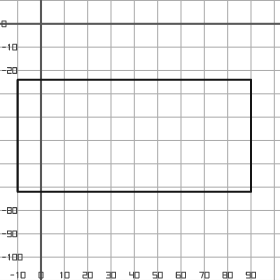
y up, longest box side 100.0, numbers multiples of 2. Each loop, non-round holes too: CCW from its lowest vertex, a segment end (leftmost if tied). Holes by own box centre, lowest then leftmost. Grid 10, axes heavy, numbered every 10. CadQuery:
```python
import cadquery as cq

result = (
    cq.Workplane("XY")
    .moveTo(-10.0, -72.0)
    .lineTo(90.0, -72.0)
    .lineTo(90.0, -24.0)
    .lineTo(-10.0, -24.0)
    .close()
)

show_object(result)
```